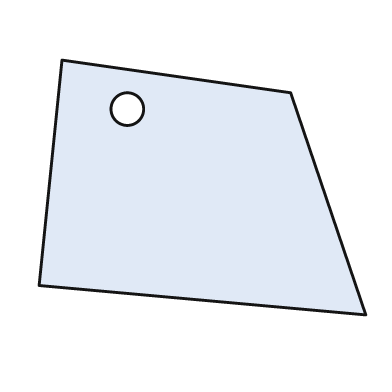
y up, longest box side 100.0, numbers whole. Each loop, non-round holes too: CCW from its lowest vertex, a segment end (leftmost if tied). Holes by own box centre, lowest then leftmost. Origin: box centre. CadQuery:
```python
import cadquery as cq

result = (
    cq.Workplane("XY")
    .moveTo(50.0, -39.0)
    .lineTo(27.0, 29.0)
    .lineTo(-43.0, 39.0)
    .lineTo(-50.0, -30.0)
    .close()
    .moveTo(-23.0, 24.0)
    .circle(5.0)
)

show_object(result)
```